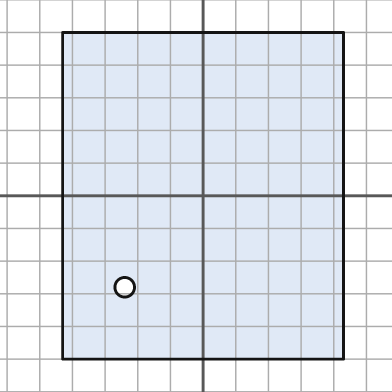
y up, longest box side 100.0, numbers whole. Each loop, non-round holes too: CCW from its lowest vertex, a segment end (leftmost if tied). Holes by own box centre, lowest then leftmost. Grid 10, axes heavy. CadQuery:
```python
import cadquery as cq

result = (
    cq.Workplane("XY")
    .moveTo(-43.0, -50.0)
    .lineTo(43.0, -50.0)
    .lineTo(43.0, 50.0)
    .lineTo(-43.0, 50.0)
    .close()
    .moveTo(-24.0, -28.0)
    .circle(3.0)
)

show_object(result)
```